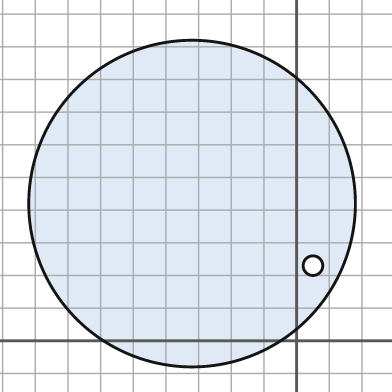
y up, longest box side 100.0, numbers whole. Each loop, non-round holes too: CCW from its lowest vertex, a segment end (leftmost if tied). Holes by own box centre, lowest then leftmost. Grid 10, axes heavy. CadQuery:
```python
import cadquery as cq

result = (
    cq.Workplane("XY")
    .moveTo(-32.0, 42.0)
    .circle(50.0)
    .moveTo(5.0, 23.0)
    .circle(3.0)
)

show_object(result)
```